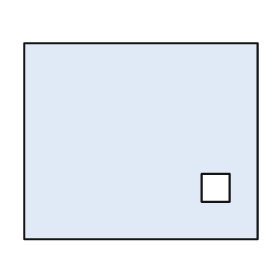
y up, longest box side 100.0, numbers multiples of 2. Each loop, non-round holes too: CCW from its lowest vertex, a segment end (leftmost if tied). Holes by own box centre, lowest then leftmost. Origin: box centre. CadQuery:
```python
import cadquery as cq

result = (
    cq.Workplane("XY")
    .moveTo(-50.0, -42.0)
    .lineTo(50.0, -42.0)
    .lineTo(50.0, 42.0)
    .lineTo(-50.0, 42.0)
    .close()
    .moveTo(26.0, -26.0)
    .lineTo(38.0, -26.0)
    .lineTo(38.0, -14.0)
    .lineTo(26.0, -14.0)
    .close()
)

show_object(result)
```